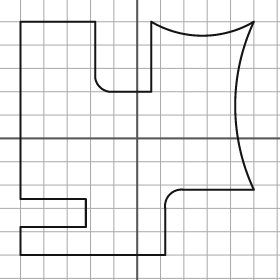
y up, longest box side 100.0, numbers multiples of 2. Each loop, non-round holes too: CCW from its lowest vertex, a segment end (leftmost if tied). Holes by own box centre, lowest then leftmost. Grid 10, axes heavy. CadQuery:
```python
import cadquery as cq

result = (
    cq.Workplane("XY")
    .moveTo(-50.0, -50.0)
    .lineTo(12.0, -50.0)
    .lineTo(12.0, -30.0)
    .threePointArc((14.0, -24.0), (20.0, -22.0))
    .lineTo(50.0, -22.0)
    .threePointArc((42.0, 14.0), (50.0, 50.0))
    .threePointArc((28.0, 44.0), (6.0, 50.0))
    .lineTo(6.0, 20.0)
    .lineTo(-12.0, 20.0)
    .threePointArc((-16.0, 22.0), (-18.0, 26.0))
    .lineTo(-18.0, 50.0)
    .lineTo(-50.0, 50.0)
    .lineTo(-50.0, -26.0)
    .lineTo(-22.0, -26.0)
    .lineTo(-22.0, -38.0)
    .lineTo(-50.0, -38.0)
    .close()
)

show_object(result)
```